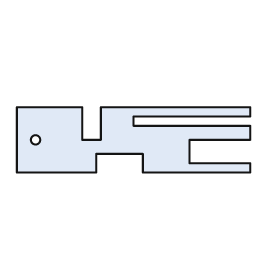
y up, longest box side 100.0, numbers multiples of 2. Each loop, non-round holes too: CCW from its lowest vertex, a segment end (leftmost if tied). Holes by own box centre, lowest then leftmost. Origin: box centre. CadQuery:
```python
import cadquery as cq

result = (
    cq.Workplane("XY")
    .moveTo(-50.0, -14.0)
    .lineTo(-16.0, -14.0)
    .lineTo(-16.0, -6.0)
    .lineTo(4.0, -6.0)
    .lineTo(4.0, -14.0)
    .lineTo(50.0, -14.0)
    .lineTo(50.0, -10.0)
    .lineTo(24.0, -10.0)
    .lineTo(24.0, 0.0)
    .lineTo(50.0, 0.0)
    .lineTo(50.0, 6.0)
    .lineTo(0.0, 6.0)
    .lineTo(0.0, 10.0)
    .lineTo(50.0, 10.0)
    .lineTo(50.0, 14.0)
    .lineTo(-14.0, 14.0)
    .lineTo(-14.0, 0.0)
    .lineTo(-22.0, 0.0)
    .lineTo(-22.0, 14.0)
    .lineTo(-50.0, 14.0)
    .close()
    .moveTo(-42.0, 0.0)
    .circle(2.0)
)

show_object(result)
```